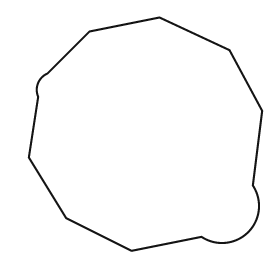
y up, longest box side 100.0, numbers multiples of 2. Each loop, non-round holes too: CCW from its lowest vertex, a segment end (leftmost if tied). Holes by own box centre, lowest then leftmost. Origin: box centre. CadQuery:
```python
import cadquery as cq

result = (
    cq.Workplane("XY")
    .moveTo(-6.0, -50.0)
    .lineTo(24.0, -44.0)
    .threePointArc((44.0, -42.0), (46.0, -22.0))
    .lineTo(50.0, 10.0)
    .lineTo(36.0, 36.0)
    .lineTo(6.0, 50.0)
    .lineTo(-24.0, 44.0)
    .lineTo(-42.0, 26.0)
    .threePointArc((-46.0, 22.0), (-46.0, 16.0))
    .lineTo(-50.0, -10.0)
    .lineTo(-34.0, -36.0)
    .close()
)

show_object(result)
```